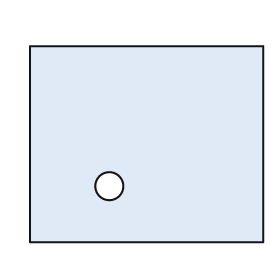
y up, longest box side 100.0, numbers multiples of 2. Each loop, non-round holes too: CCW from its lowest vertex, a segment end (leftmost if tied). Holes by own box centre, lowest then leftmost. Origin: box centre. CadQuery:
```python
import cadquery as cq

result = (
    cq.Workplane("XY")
    .moveTo(-50.0, -42.0)
    .lineTo(50.0, -42.0)
    .lineTo(50.0, 42.0)
    .lineTo(-50.0, 42.0)
    .close()
    .moveTo(-16.0, -18.0)
    .circle(6.0)
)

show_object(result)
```